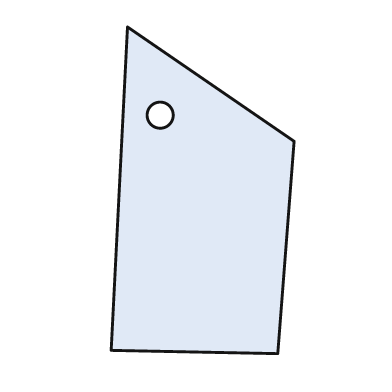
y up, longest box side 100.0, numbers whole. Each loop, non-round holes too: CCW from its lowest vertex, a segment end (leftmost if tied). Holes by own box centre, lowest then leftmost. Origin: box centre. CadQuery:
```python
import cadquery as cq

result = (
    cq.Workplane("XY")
    .moveTo(23.0, -50.0)
    .lineTo(28.0, 15.0)
    .lineTo(-23.0, 50.0)
    .lineTo(-28.0, -49.0)
    .close()
    .moveTo(-13.0, 23.0)
    .circle(4.0)
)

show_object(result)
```